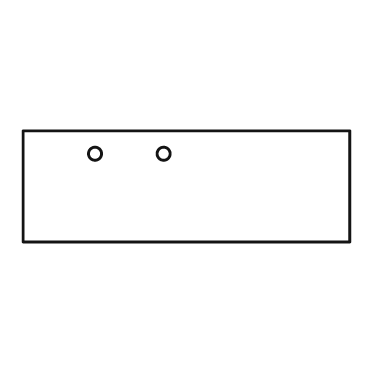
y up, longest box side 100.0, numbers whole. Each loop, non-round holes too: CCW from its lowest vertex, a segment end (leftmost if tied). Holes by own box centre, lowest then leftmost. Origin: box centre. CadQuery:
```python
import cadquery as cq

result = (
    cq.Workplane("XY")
    .moveTo(-50.0, -17.0)
    .lineTo(50.0, -17.0)
    .lineTo(50.0, 17.0)
    .lineTo(-50.0, 17.0)
    .close()
    .moveTo(-28.0, 10.0)
    .circle(2.0)
    .moveTo(-7.0, 10.0)
    .circle(2.0)
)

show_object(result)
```